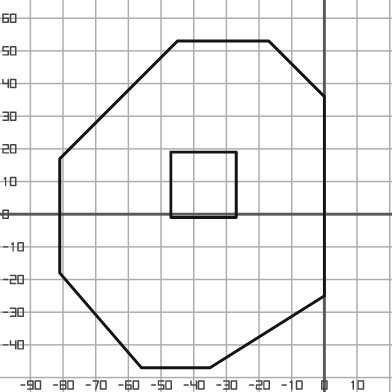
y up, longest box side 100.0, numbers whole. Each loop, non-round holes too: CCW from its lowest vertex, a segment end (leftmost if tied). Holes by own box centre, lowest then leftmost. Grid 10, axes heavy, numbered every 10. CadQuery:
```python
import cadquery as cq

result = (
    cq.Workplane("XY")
    .moveTo(-56.0, -47.0)
    .lineTo(-35.0, -47.0)
    .lineTo(0.0, -25.0)
    .lineTo(0.0, 36.0)
    .lineTo(-17.0, 53.0)
    .lineTo(-45.0, 53.0)
    .lineTo(-81.0, 17.0)
    .lineTo(-81.0, -18.0)
    .close()
    .moveTo(-47.0, -1.0)
    .lineTo(-27.0, -1.0)
    .lineTo(-27.0, 19.0)
    .lineTo(-47.0, 19.0)
    .close()
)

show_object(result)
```